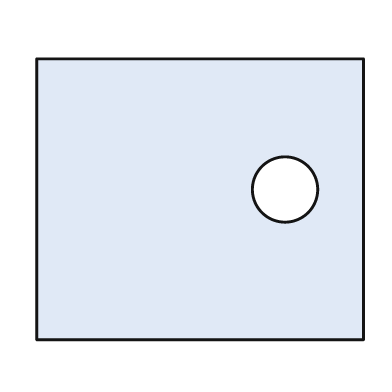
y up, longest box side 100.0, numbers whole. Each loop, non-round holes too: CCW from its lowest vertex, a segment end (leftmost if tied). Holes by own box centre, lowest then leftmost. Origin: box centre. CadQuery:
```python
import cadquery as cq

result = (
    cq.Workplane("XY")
    .moveTo(-50.0, -43.0)
    .lineTo(50.0, -43.0)
    .lineTo(50.0, 43.0)
    .lineTo(-50.0, 43.0)
    .close()
    .moveTo(26.0, 3.0)
    .circle(10.0)
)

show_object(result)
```